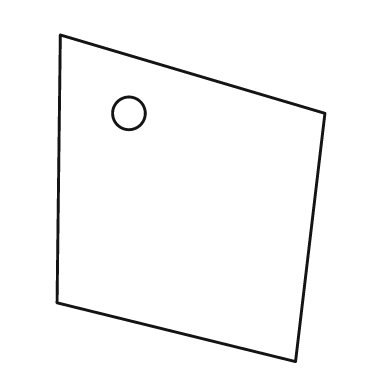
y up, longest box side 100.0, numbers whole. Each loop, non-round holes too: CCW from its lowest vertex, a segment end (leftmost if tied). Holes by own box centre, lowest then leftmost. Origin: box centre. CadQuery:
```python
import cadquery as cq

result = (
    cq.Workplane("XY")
    .moveTo(32.0, -50.0)
    .lineTo(41.0, 26.0)
    .lineTo(-40.0, 50.0)
    .lineTo(-41.0, -32.0)
    .close()
    .moveTo(-19.0, 26.0)
    .circle(5.0)
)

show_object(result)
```